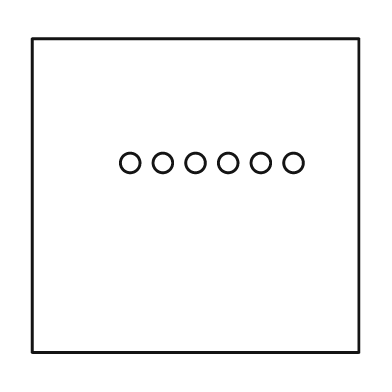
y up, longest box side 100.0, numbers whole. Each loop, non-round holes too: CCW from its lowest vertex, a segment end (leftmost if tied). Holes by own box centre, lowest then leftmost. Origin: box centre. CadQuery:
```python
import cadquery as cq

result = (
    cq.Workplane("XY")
    .moveTo(-50.0, -48.0)
    .lineTo(50.0, -48.0)
    .lineTo(50.0, 48.0)
    .lineTo(-50.0, 48.0)
    .close()
    .moveTo(-20.0, 10.0)
    .circle(3.0)
    .moveTo(-10.0, 10.0)
    .circle(3.0)
    .moveTo(0.0, 10.0)
    .circle(3.0)
    .moveTo(10.0, 10.0)
    .circle(3.0)
    .moveTo(20.0, 10.0)
    .circle(3.0)
    .moveTo(30.0, 10.0)
    .circle(3.0)
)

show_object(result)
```